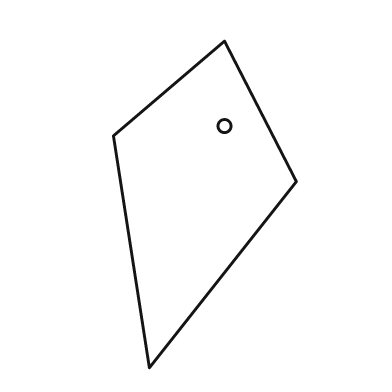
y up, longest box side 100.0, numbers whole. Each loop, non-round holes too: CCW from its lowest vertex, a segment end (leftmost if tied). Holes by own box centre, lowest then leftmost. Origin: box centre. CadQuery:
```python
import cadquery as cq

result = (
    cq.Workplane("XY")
    .moveTo(-17.0, -50.0)
    .lineTo(28.0, 7.0)
    .lineTo(6.0, 50.0)
    .lineTo(-28.0, 21.0)
    .close()
    .moveTo(6.0, 24.0)
    .circle(2.0)
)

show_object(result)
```